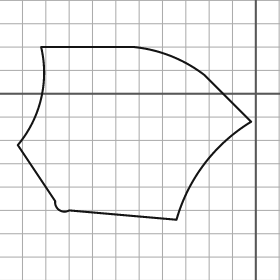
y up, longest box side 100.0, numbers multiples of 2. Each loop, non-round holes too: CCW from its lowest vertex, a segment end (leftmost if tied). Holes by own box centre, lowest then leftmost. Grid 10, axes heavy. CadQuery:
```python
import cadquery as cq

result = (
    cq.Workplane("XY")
    .moveTo(-34.0, -54.0)
    .threePointArc((-22.0, -30.0), (-2.0, -12.0))
    .lineTo(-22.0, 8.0)
    .threePointArc((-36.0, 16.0), (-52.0, 20.0))
    .lineTo(-92.0, 20.0)
    .threePointArc((-92.0, -2.0), (-102.0, -22.0))
    .lineTo(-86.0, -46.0)
    .threePointArc((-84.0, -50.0), (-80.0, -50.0))
    .close()
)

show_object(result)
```